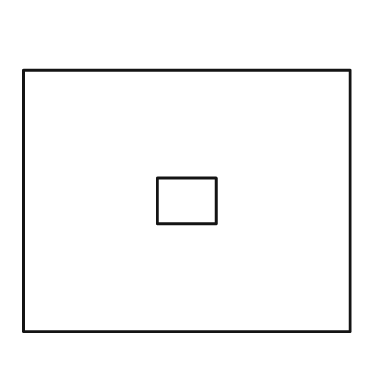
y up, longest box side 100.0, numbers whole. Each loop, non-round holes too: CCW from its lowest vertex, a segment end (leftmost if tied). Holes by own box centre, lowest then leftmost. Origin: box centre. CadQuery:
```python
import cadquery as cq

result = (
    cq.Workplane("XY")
    .moveTo(-50.0, -40.0)
    .lineTo(50.0, -40.0)
    .lineTo(50.0, 40.0)
    .lineTo(-50.0, 40.0)
    .close()
    .moveTo(-9.0, -7.0)
    .lineTo(9.0, -7.0)
    .lineTo(9.0, 7.0)
    .lineTo(-9.0, 7.0)
    .close()
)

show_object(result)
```